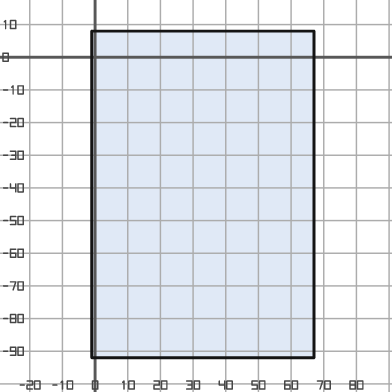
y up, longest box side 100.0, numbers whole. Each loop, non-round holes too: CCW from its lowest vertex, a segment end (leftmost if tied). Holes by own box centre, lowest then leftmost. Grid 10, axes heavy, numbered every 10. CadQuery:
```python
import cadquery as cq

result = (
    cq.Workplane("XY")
    .moveTo(-1.0, -92.0)
    .lineTo(67.0, -92.0)
    .lineTo(67.0, 8.0)
    .lineTo(-1.0, 8.0)
    .close()
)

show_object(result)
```